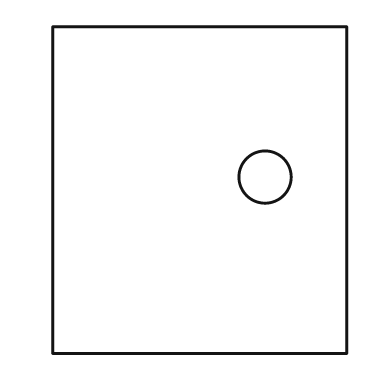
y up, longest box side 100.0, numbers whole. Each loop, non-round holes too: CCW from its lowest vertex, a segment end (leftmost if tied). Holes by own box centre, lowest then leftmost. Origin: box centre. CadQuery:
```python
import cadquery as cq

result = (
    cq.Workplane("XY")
    .moveTo(-45.0, -50.0)
    .lineTo(45.0, -50.0)
    .lineTo(45.0, 50.0)
    .lineTo(-45.0, 50.0)
    .close()
    .moveTo(20.0, 4.0)
    .circle(8.0)
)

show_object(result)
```